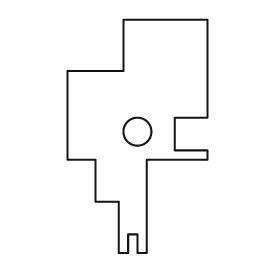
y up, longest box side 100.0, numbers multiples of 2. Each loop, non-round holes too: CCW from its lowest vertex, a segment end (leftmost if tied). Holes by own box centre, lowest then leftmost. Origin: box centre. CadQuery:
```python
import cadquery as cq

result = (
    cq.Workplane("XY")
    .moveTo(-8.0, -50.0)
    .lineTo(-4.0, -50.0)
    .lineTo(-4.0, -42.0)
    .lineTo(0.0, -42.0)
    .lineTo(0.0, -50.0)
    .lineTo(4.0, -50.0)
    .lineTo(4.0, -10.0)
    .lineTo(30.0, -10.0)
    .lineTo(30.0, -6.0)
    .lineTo(16.0, -6.0)
    .lineTo(16.0, 8.0)
    .lineTo(30.0, 8.0)
    .lineTo(30.0, 50.0)
    .lineTo(-6.0, 50.0)
    .lineTo(-6.0, 28.0)
    .lineTo(-30.0, 28.0)
    .lineTo(-30.0, -10.0)
    .lineTo(-18.0, -10.0)
    .lineTo(-18.0, -28.0)
    .lineTo(-8.0, -28.0)
    .close()
    .moveTo(0.0, 2.0)
    .circle(6.0)
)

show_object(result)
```